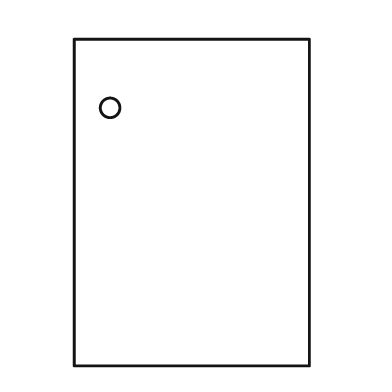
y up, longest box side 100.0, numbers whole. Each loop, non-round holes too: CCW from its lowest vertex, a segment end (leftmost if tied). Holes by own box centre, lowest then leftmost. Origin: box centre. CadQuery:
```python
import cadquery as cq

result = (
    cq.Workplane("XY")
    .moveTo(-36.0, -50.0)
    .lineTo(36.0, -50.0)
    .lineTo(36.0, 50.0)
    .lineTo(-36.0, 50.0)
    .close()
    .moveTo(-25.0, 29.0)
    .circle(3.0)
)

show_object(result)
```